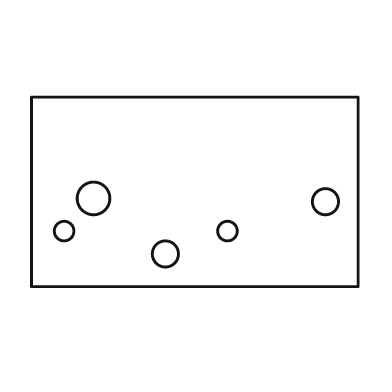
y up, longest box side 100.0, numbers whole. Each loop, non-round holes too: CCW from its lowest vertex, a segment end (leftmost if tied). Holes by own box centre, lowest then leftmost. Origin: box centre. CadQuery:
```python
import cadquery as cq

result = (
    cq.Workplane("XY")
    .moveTo(-50.0, -29.0)
    .lineTo(50.0, -29.0)
    .lineTo(50.0, 29.0)
    .lineTo(-50.0, 29.0)
    .close()
    .moveTo(-9.0, -19.0)
    .circle(4.0)
    .moveTo(-40.0, -12.0)
    .circle(3.0)
    .moveTo(10.0, -12.0)
    .circle(3.0)
    .moveTo(40.0, -3.0)
    .circle(4.0)
    .moveTo(-31.0, -2.0)
    .circle(5.0)
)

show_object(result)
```